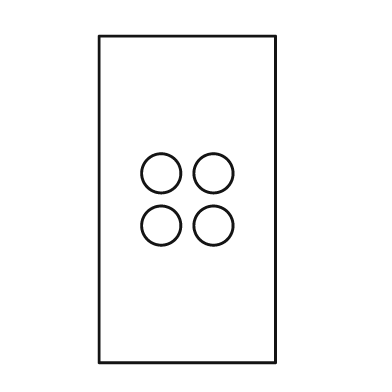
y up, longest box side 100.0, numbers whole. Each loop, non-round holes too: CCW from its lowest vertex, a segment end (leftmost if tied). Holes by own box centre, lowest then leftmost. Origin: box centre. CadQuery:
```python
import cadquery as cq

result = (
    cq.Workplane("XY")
    .moveTo(-27.0, -50.0)
    .lineTo(27.0, -50.0)
    .lineTo(27.0, 50.0)
    .lineTo(-27.0, 50.0)
    .close()
    .moveTo(-8.0, -8.0)
    .circle(6.0)
    .moveTo(8.0, -8.0)
    .circle(6.0)
    .moveTo(-8.0, 8.0)
    .circle(6.0)
    .moveTo(8.0, 8.0)
    .circle(6.0)
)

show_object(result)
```